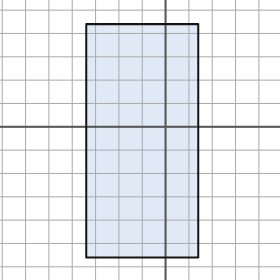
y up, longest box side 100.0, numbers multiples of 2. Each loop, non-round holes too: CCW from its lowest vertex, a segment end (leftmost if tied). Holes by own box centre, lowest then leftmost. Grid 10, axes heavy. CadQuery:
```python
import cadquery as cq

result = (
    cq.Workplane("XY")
    .moveTo(-34.0, -56.0)
    .lineTo(14.0, -56.0)
    .lineTo(14.0, 44.0)
    .lineTo(-34.0, 44.0)
    .close()
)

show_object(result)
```